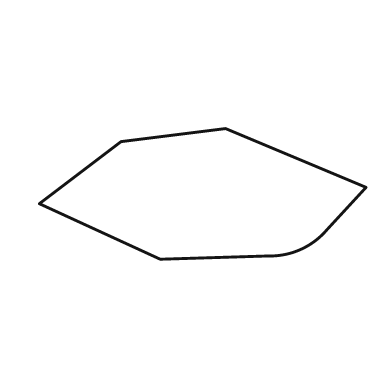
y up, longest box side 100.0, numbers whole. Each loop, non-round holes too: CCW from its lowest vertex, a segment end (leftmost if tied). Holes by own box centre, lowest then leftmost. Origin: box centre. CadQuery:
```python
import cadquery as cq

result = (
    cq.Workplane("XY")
    .moveTo(-13.0, -20.0)
    .lineTo(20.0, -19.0)
    .threePointArc((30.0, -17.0), (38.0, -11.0))
    .lineTo(50.0, 2.0)
    .lineTo(7.0, 20.0)
    .lineTo(-25.0, 16.0)
    .lineTo(-50.0, -3.0)
    .close()
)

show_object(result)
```